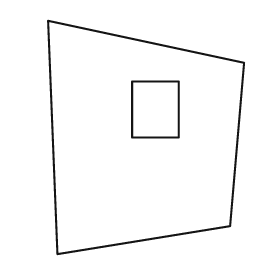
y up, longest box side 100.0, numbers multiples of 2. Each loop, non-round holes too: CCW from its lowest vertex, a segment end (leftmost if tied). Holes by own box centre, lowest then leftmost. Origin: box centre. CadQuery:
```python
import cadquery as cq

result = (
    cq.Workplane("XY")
    .moveTo(-38.0, -50.0)
    .lineTo(36.0, -38.0)
    .lineTo(42.0, 32.0)
    .lineTo(-42.0, 50.0)
    .close()
    .moveTo(-6.0, 0.0)
    .lineTo(14.0, 0.0)
    .lineTo(14.0, 24.0)
    .lineTo(-6.0, 24.0)
    .close()
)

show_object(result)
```